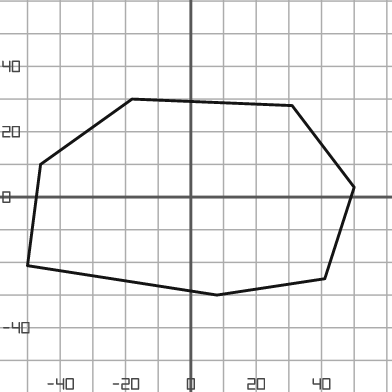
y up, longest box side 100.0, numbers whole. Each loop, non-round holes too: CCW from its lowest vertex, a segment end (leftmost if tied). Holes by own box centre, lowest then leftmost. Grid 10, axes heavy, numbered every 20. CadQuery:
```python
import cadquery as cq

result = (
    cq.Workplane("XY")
    .moveTo(8.0, -30.0)
    .lineTo(41.0, -25.0)
    .lineTo(50.0, 3.0)
    .lineTo(31.0, 28.0)
    .lineTo(-18.0, 30.0)
    .lineTo(-46.0, 10.0)
    .lineTo(-50.0, -21.0)
    .close()
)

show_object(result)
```